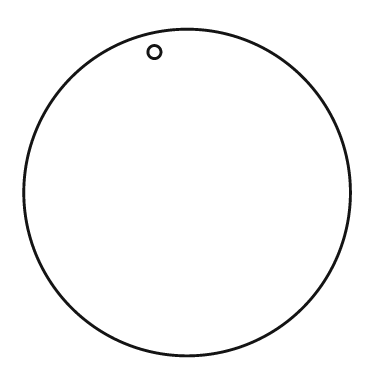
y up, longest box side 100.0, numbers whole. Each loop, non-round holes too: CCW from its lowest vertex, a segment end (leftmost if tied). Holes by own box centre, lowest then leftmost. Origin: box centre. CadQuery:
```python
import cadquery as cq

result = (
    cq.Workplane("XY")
    .moveTo(0.0, 0.0)
    .circle(50.0)
    .moveTo(-10.0, 43.0)
    .circle(2.0)
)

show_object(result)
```